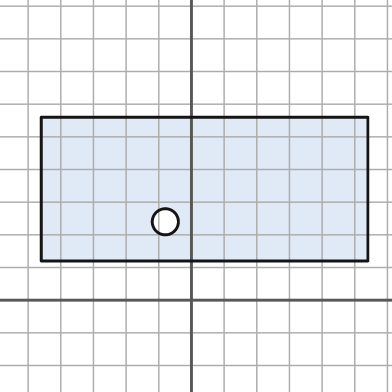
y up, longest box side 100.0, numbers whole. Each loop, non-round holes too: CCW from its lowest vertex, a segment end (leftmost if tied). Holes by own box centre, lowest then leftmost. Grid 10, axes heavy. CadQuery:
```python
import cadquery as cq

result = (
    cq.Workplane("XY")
    .moveTo(-46.0, 12.0)
    .lineTo(54.0, 12.0)
    .lineTo(54.0, 56.0)
    .lineTo(-46.0, 56.0)
    .close()
    .moveTo(-8.0, 24.0)
    .circle(4.0)
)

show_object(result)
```